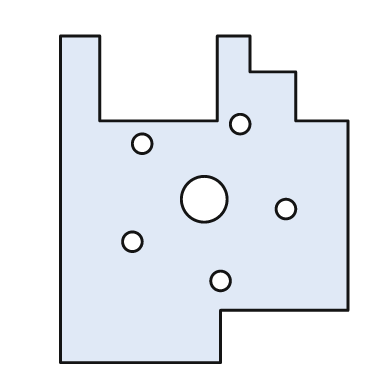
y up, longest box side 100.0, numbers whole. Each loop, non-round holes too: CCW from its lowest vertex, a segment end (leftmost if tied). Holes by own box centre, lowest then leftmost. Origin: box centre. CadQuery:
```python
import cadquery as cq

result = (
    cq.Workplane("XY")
    .moveTo(-44.0, -50.0)
    .lineTo(5.0, -50.0)
    .lineTo(5.0, -34.0)
    .lineTo(44.0, -34.0)
    .lineTo(44.0, 24.0)
    .lineTo(28.0, 24.0)
    .lineTo(28.0, 39.0)
    .lineTo(14.0, 39.0)
    .lineTo(14.0, 50.0)
    .lineTo(4.0, 50.0)
    .lineTo(4.0, 24.0)
    .lineTo(-32.0, 24.0)
    .lineTo(-32.0, 50.0)
    .lineTo(-44.0, 50.0)
    .close()
    .moveTo(5.0, -25.0)
    .circle(3.0)
    .moveTo(-22.0, -13.0)
    .circle(3.0)
    .moveTo(25.0, -3.0)
    .circle(3.0)
    .moveTo(0.0, 0.0)
    .circle(7.0)
    .moveTo(-19.0, 17.0)
    .circle(3.0)
    .moveTo(11.0, 23.0)
    .circle(3.0)
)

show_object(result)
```